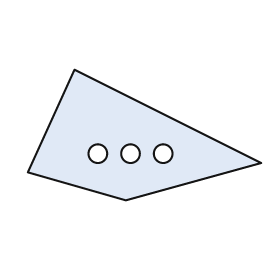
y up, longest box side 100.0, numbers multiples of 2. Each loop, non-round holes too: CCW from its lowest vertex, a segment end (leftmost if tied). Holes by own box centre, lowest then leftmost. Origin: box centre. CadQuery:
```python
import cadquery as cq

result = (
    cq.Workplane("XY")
    .moveTo(-8.0, -28.0)
    .lineTo(50.0, -12.0)
    .lineTo(-30.0, 28.0)
    .lineTo(-50.0, -16.0)
    .close()
    .moveTo(-20.0, -8.0)
    .circle(4.0)
    .moveTo(-6.0, -8.0)
    .circle(4.0)
    .moveTo(8.0, -8.0)
    .circle(4.0)
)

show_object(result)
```